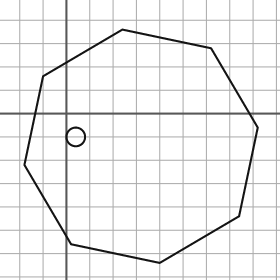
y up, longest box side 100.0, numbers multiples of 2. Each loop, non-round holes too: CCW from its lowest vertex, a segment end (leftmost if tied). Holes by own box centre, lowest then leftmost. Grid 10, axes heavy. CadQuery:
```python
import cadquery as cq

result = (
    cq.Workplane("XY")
    .moveTo(40.0, -64.0)
    .lineTo(74.0, -44.0)
    .lineTo(82.0, -6.0)
    .lineTo(62.0, 28.0)
    .lineTo(24.0, 36.0)
    .lineTo(-10.0, 16.0)
    .lineTo(-18.0, -22.0)
    .lineTo(2.0, -56.0)
    .close()
    .moveTo(4.0, -10.0)
    .circle(4.0)
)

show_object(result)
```